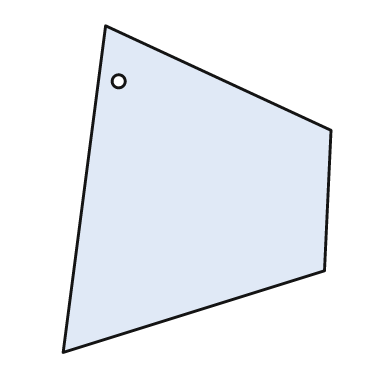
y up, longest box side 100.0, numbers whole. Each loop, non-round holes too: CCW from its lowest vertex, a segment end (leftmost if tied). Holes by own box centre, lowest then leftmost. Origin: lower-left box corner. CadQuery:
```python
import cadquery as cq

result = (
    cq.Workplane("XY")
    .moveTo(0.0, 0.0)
    .lineTo(80.0, 25.0)
    .lineTo(82.0, 68.0)
    .lineTo(13.0, 100.0)
    .close()
    .moveTo(17.0, 83.0)
    .circle(2.0)
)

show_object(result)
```